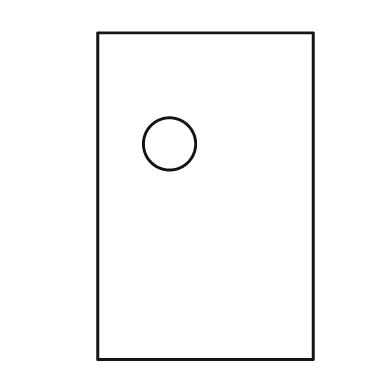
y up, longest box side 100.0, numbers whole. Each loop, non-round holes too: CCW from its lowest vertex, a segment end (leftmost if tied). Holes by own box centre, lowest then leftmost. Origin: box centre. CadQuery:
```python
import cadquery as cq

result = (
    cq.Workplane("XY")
    .moveTo(-33.0, -50.0)
    .lineTo(33.0, -50.0)
    .lineTo(33.0, 50.0)
    .lineTo(-33.0, 50.0)
    .close()
    .moveTo(-11.0, 16.0)
    .circle(8.0)
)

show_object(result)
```